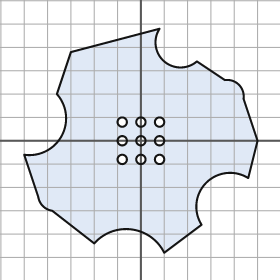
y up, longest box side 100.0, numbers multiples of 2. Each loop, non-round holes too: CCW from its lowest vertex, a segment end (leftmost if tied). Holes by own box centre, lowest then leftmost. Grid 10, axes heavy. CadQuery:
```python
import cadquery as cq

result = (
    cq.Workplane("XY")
    .moveTo(10.0, -48.0)
    .lineTo(26.0, -36.0)
    .threePointArc((28.0, -18.0), (46.0, -16.0))
    .lineTo(50.0, 0.0)
    .lineTo(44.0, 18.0)
    .threePointArc((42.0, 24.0), (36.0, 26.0))
    .lineTo(24.0, 34.0)
    .threePointArc((10.0, 34.0), (8.0, 48.0))
    .lineTo(-30.0, 38.0)
    .lineTo(-36.0, 20.0)
    .threePointArc((-34.0, 2.0), (-50.0, -6.0))
    .lineTo(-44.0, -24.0)
    .threePointArc((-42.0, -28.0), (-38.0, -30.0))
    .lineTo(-20.0, -44.0)
    .threePointArc((-4.0, -38.0), (10.0, -48.0))
    .close()
    .moveTo(-8.0, -8.0)
    .circle(2.0)
    .moveTo(0.0, -8.0)
    .circle(2.0)
    .moveTo(8.0, -8.0)
    .circle(2.0)
    .moveTo(-8.0, 0.0)
    .circle(2.0)
    .moveTo(0.0, 0.0)
    .circle(2.0)
    .moveTo(8.0, 0.0)
    .circle(2.0)
    .moveTo(-8.0, 8.0)
    .circle(2.0)
    .moveTo(0.0, 8.0)
    .circle(2.0)
    .moveTo(8.0, 8.0)
    .circle(2.0)
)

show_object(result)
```